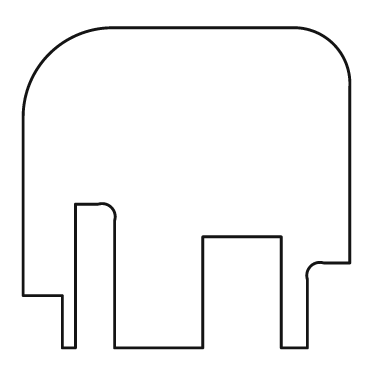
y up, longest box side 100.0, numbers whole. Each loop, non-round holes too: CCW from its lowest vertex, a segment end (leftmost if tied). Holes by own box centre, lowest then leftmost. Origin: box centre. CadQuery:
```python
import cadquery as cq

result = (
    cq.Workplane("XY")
    .moveTo(-38.0, -49.0)
    .lineTo(-34.0, -49.0)
    .lineTo(-34.0, -5.0)
    .lineTo(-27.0, -5.0)
    .threePointArc((-23.0, -6.0), (-22.0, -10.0))
    .lineTo(-22.0, -49.0)
    .lineTo(5.0, -49.0)
    .lineTo(5.0, -15.0)
    .lineTo(29.0, -15.0)
    .lineTo(29.0, -49.0)
    .lineTo(37.0, -49.0)
    .lineTo(37.0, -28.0)
    .threePointArc((38.0, -24.0), (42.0, -23.0))
    .lineTo(50.0, -23.0)
    .lineTo(50.0, 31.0)
    .threePointArc((45.0, 44.0), (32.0, 49.0))
    .lineTo(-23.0, 49.0)
    .threePointArc((-42.0, 41.0), (-50.0, 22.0))
    .lineTo(-50.0, -33.0)
    .lineTo(-38.0, -33.0)
    .close()
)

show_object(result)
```